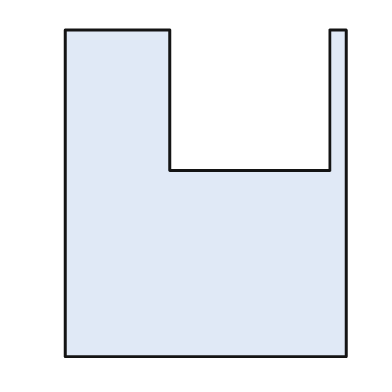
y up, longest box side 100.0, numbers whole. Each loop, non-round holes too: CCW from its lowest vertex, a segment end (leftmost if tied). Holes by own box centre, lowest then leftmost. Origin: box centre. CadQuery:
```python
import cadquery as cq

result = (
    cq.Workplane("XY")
    .moveTo(-43.0, -50.0)
    .lineTo(43.0, -50.0)
    .lineTo(43.0, 50.0)
    .lineTo(38.0, 50.0)
    .lineTo(38.0, 7.0)
    .lineTo(-11.0, 7.0)
    .lineTo(-11.0, 50.0)
    .lineTo(-43.0, 50.0)
    .close()
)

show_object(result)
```